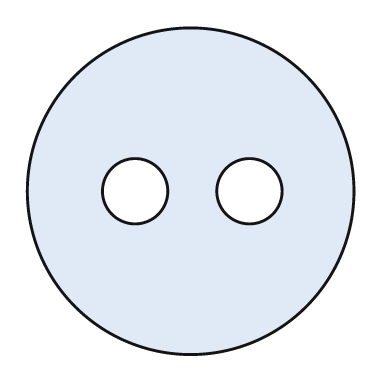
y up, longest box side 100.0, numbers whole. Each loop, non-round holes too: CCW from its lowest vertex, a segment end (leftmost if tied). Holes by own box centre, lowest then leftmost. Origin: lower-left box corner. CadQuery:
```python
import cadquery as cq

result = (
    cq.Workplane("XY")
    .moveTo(50.0, 50.0)
    .circle(50.0)
    .moveTo(33.0, 50.0)
    .circle(10.0)
    .moveTo(68.0, 50.0)
    .circle(10.0)
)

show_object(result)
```